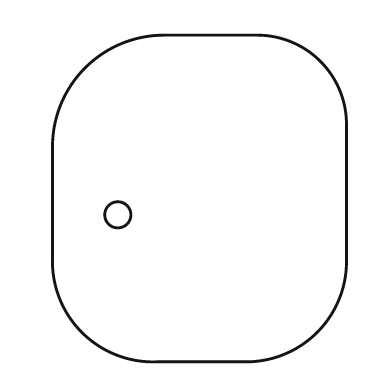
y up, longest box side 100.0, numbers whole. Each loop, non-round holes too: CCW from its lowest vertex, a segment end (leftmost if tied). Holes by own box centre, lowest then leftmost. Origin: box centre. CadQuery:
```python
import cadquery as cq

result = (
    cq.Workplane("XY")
    .moveTo(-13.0, -50.0)
    .lineTo(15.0, -50.0)
    .threePointArc((36.0, -41.0), (45.0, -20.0))
    .lineTo(45.0, 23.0)
    .threePointArc((37.0, 42.0), (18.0, 50.0))
    .lineTo(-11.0, 50.0)
    .threePointArc((-35.0, 40.0), (-45.0, 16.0))
    .lineTo(-45.0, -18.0)
    .threePointArc((-36.0, -41.0), (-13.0, -50.0))
    .close()
    .moveTo(-25.0, -5.0)
    .circle(4.0)
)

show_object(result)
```